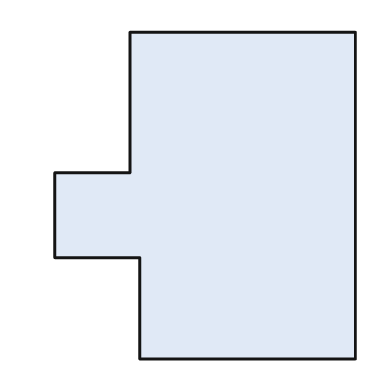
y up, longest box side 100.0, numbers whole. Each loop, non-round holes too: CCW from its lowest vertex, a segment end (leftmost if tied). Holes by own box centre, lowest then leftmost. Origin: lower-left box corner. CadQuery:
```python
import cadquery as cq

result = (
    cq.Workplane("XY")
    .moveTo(26.0, 0.0)
    .lineTo(92.0, 0.0)
    .lineTo(92.0, 100.0)
    .lineTo(23.0, 100.0)
    .lineTo(23.0, 57.0)
    .lineTo(0.0, 57.0)
    .lineTo(0.0, 31.0)
    .lineTo(26.0, 31.0)
    .close()
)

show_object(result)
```